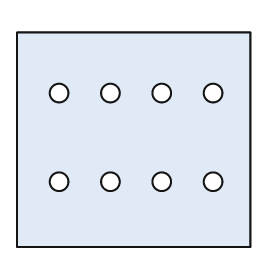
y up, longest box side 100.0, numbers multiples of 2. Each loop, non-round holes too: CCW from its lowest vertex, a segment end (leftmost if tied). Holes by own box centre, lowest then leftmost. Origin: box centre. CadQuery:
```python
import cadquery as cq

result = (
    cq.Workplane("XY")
    .moveTo(-50.0, -46.0)
    .lineTo(50.0, -46.0)
    .lineTo(50.0, 46.0)
    .lineTo(-50.0, 46.0)
    .close()
    .moveTo(-32.0, -18.0)
    .circle(4.0)
    .moveTo(-10.0, -18.0)
    .circle(4.0)
    .moveTo(12.0, -18.0)
    .circle(4.0)
    .moveTo(34.0, -18.0)
    .circle(4.0)
    .moveTo(-32.0, 20.0)
    .circle(4.0)
    .moveTo(-10.0, 20.0)
    .circle(4.0)
    .moveTo(12.0, 20.0)
    .circle(4.0)
    .moveTo(34.0, 20.0)
    .circle(4.0)
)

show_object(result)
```